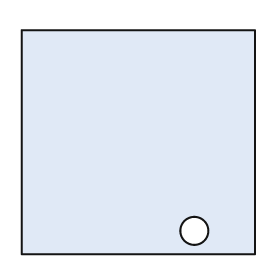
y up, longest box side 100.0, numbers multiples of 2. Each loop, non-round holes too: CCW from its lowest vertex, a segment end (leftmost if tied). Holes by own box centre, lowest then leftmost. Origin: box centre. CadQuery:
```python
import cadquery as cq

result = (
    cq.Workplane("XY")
    .moveTo(-50.0, -48.0)
    .lineTo(50.0, -48.0)
    .lineTo(50.0, 48.0)
    .lineTo(-50.0, 48.0)
    .close()
    .moveTo(24.0, -38.0)
    .circle(6.0)
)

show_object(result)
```